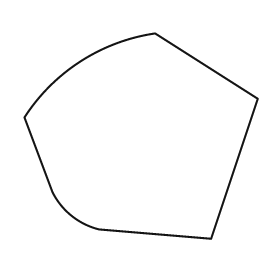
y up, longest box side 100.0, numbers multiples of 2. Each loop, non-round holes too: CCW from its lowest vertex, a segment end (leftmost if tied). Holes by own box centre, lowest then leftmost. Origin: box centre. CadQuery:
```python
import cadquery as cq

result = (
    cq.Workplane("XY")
    .moveTo(30.0, -44.0)
    .lineTo(50.0, 16.0)
    .lineTo(6.0, 44.0)
    .threePointArc((-26.0, 32.0), (-50.0, 8.0))
    .lineTo(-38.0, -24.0)
    .threePointArc((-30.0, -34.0), (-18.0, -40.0))
    .close()
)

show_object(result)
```